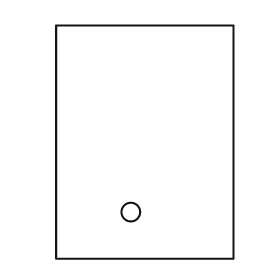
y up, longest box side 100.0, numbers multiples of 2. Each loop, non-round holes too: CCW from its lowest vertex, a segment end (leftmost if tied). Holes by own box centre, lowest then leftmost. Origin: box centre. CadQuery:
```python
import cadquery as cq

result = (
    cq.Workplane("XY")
    .moveTo(-38.0, -50.0)
    .lineTo(38.0, -50.0)
    .lineTo(38.0, 50.0)
    .lineTo(-38.0, 50.0)
    .close()
    .moveTo(-6.0, -30.0)
    .circle(4.0)
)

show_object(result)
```